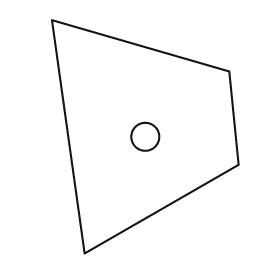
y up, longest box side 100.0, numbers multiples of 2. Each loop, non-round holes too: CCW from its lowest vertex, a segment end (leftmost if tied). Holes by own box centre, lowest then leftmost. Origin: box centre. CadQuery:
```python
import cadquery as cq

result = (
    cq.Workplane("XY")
    .moveTo(-26.0, -50.0)
    .lineTo(40.0, -12.0)
    .lineTo(36.0, 28.0)
    .lineTo(-40.0, 50.0)
    .close()
    .moveTo(0.0, 0.0)
    .circle(6.0)
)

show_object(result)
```